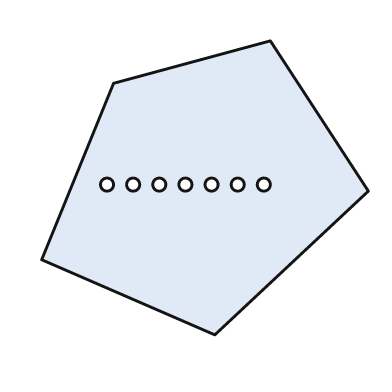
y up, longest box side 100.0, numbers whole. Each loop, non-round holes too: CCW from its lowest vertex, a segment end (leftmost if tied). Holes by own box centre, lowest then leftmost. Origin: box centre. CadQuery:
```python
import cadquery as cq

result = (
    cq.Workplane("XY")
    .moveTo(3.0, -45.0)
    .lineTo(50.0, -1.0)
    .lineTo(20.0, 45.0)
    .lineTo(-28.0, 32.0)
    .lineTo(-50.0, -22.0)
    .close()
    .moveTo(-30.0, 1.0)
    .circle(2.0)
    .moveTo(-22.0, 1.0)
    .circle(2.0)
    .moveTo(-14.0, 1.0)
    .circle(2.0)
    .moveTo(-6.0, 1.0)
    .circle(2.0)
    .moveTo(2.0, 1.0)
    .circle(2.0)
    .moveTo(10.0, 1.0)
    .circle(2.0)
    .moveTo(18.0, 1.0)
    .circle(2.0)
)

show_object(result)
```